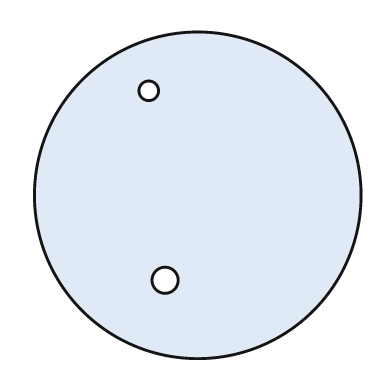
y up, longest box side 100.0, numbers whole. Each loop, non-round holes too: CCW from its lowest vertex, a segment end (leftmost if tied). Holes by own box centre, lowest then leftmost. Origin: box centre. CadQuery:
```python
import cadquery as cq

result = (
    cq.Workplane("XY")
    .moveTo(0.0, 0.0)
    .circle(50.0)
    .moveTo(-10.0, -26.0)
    .circle(4.0)
    .moveTo(-15.0, 32.0)
    .circle(3.0)
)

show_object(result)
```